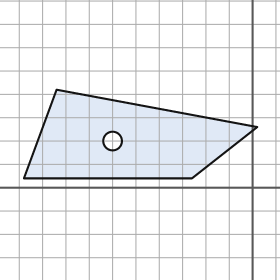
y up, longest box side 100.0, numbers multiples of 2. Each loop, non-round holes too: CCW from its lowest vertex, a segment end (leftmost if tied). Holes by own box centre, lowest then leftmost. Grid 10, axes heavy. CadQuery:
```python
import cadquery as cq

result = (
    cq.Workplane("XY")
    .moveTo(-98.0, 4.0)
    .lineTo(-26.0, 4.0)
    .lineTo(2.0, 26.0)
    .lineTo(-84.0, 42.0)
    .close()
    .moveTo(-60.0, 20.0)
    .circle(4.0)
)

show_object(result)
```